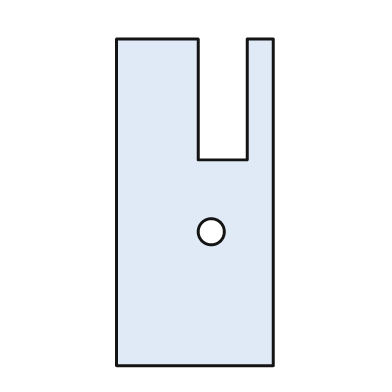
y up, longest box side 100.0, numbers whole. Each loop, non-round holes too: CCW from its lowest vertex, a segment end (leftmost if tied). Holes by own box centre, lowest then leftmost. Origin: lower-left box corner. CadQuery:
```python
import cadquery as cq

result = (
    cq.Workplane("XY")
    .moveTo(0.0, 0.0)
    .lineTo(48.0, 0.0)
    .lineTo(48.0, 100.0)
    .lineTo(40.0, 100.0)
    .lineTo(40.0, 63.0)
    .lineTo(25.0, 63.0)
    .lineTo(25.0, 100.0)
    .lineTo(0.0, 100.0)
    .close()
    .moveTo(29.0, 41.0)
    .circle(4.0)
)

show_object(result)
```